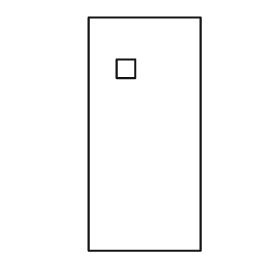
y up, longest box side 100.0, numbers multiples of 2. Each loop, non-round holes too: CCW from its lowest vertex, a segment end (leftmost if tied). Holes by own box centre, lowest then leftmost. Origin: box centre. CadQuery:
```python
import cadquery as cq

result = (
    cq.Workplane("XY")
    .moveTo(-24.0, -50.0)
    .lineTo(24.0, -50.0)
    .lineTo(24.0, 50.0)
    .lineTo(-24.0, 50.0)
    .close()
    .moveTo(-12.0, 24.0)
    .lineTo(-4.0, 24.0)
    .lineTo(-4.0, 32.0)
    .lineTo(-12.0, 32.0)
    .close()
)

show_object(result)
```